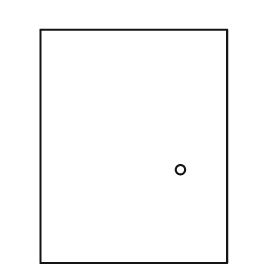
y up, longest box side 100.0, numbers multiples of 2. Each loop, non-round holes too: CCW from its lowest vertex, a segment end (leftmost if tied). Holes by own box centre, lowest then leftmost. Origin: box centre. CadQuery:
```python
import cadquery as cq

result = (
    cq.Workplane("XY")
    .moveTo(-40.0, -50.0)
    .lineTo(40.0, -50.0)
    .lineTo(40.0, 50.0)
    .lineTo(-40.0, 50.0)
    .close()
    .moveTo(20.0, -10.0)
    .circle(2.0)
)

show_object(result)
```